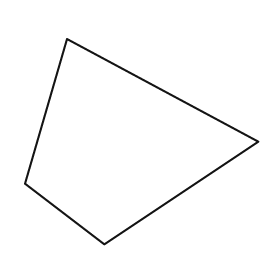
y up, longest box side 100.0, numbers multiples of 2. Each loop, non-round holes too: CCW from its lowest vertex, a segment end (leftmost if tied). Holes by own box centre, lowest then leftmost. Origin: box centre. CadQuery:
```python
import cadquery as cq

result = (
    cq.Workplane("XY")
    .moveTo(-16.0, -44.0)
    .lineTo(50.0, 0.0)
    .lineTo(-32.0, 44.0)
    .lineTo(-50.0, -18.0)
    .close()
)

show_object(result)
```